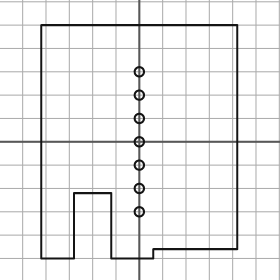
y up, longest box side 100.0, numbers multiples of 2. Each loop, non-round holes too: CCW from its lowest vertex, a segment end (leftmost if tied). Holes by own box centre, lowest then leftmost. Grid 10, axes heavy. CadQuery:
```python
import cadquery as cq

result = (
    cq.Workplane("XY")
    .moveTo(-42.0, -50.0)
    .lineTo(-28.0, -50.0)
    .lineTo(-28.0, -22.0)
    .lineTo(-12.0, -22.0)
    .lineTo(-12.0, -50.0)
    .lineTo(6.0, -50.0)
    .lineTo(6.0, -46.0)
    .lineTo(42.0, -46.0)
    .lineTo(42.0, 50.0)
    .lineTo(-42.0, 50.0)
    .close()
    .moveTo(0.0, -30.0)
    .circle(2.0)
    .moveTo(0.0, -20.0)
    .circle(2.0)
    .moveTo(0.0, -10.0)
    .circle(2.0)
    .moveTo(0.0, 0.0)
    .circle(2.0)
    .moveTo(0.0, 10.0)
    .circle(2.0)
    .moveTo(0.0, 20.0)
    .circle(2.0)
    .moveTo(0.0, 30.0)
    .circle(2.0)
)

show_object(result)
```